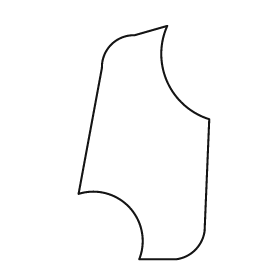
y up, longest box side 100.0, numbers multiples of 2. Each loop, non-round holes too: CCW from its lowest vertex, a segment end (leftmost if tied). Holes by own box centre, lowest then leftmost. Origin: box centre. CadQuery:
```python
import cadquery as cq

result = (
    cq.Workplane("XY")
    .moveTo(-2.0, -50.0)
    .lineTo(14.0, -50.0)
    .threePointArc((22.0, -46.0), (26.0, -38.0))
    .lineTo(28.0, 10.0)
    .threePointArc((10.0, 26.0), (10.0, 50.0))
    .lineTo(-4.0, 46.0)
    .threePointArc((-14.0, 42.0), (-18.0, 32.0))
    .lineTo(-28.0, -22.0)
    .threePointArc((-6.0, -28.0), (-2.0, -50.0))
    .close()
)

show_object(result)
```